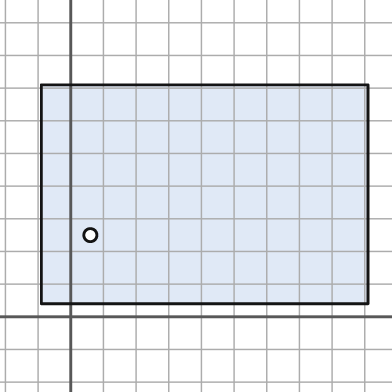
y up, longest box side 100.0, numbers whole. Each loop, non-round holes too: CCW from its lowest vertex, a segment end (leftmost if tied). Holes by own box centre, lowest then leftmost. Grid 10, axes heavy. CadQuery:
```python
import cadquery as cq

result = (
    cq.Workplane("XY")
    .moveTo(-9.0, 4.0)
    .lineTo(91.0, 4.0)
    .lineTo(91.0, 71.0)
    .lineTo(-9.0, 71.0)
    .close()
    .moveTo(6.0, 25.0)
    .circle(2.0)
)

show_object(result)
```